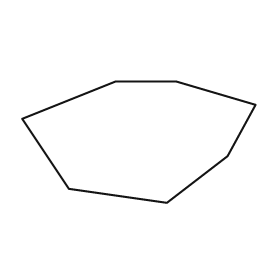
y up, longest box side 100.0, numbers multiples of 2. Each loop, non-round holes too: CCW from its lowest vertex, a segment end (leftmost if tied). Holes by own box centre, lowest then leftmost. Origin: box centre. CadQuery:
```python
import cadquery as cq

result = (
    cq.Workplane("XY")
    .moveTo(12.0, -26.0)
    .lineTo(38.0, -6.0)
    .lineTo(50.0, 16.0)
    .lineTo(16.0, 26.0)
    .lineTo(-10.0, 26.0)
    .lineTo(-50.0, 10.0)
    .lineTo(-30.0, -20.0)
    .close()
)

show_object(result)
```